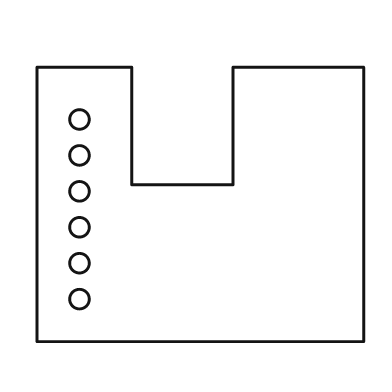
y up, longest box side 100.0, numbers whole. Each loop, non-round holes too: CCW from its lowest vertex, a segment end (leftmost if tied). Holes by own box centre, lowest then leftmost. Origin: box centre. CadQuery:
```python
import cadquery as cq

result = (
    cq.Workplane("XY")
    .moveTo(-50.0, -42.0)
    .lineTo(50.0, -42.0)
    .lineTo(50.0, 42.0)
    .lineTo(10.0, 42.0)
    .lineTo(10.0, 6.0)
    .lineTo(-21.0, 6.0)
    .lineTo(-21.0, 42.0)
    .lineTo(-50.0, 42.0)
    .close()
    .moveTo(-37.0, -29.0)
    .circle(3.0)
    .moveTo(-37.0, -18.0)
    .circle(3.0)
    .moveTo(-37.0, -7.0)
    .circle(3.0)
    .moveTo(-37.0, 4.0)
    .circle(3.0)
    .moveTo(-37.0, 15.0)
    .circle(3.0)
    .moveTo(-37.0, 26.0)
    .circle(3.0)
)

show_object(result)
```